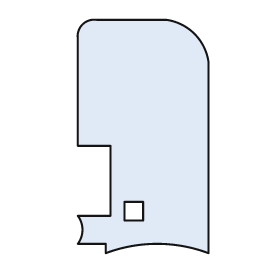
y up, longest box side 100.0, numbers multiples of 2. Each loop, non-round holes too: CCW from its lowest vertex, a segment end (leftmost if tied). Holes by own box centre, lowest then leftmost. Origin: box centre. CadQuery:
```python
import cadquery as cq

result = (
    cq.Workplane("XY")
    .moveTo(-16.0, -50.0)
    .threePointArc((6.0, -46.0), (28.0, -50.0))
    .lineTo(28.0, 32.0)
    .threePointArc((22.0, 44.0), (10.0, 50.0))
    .lineTo(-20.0, 50.0)
    .threePointArc((-26.0, 48.0), (-28.0, 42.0))
    .lineTo(-28.0, -4.0)
    .lineTo(-14.0, -4.0)
    .lineTo(-14.0, -34.0)
    .lineTo(-28.0, -34.0)
    .threePointArc((-26.0, -40.0), (-28.0, -46.0))
    .lineTo(-16.0, -46.0)
    .close()
    .moveTo(-8.0, -36.0)
    .lineTo(0.0, -36.0)
    .lineTo(0.0, -28.0)
    .lineTo(-8.0, -28.0)
    .close()
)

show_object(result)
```